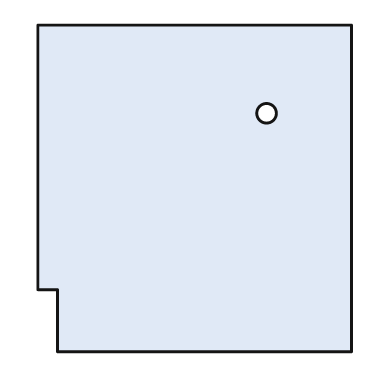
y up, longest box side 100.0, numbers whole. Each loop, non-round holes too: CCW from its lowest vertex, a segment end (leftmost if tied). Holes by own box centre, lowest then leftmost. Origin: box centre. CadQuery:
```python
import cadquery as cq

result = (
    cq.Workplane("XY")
    .moveTo(-42.0, -50.0)
    .lineTo(48.0, -50.0)
    .lineTo(48.0, 50.0)
    .lineTo(-48.0, 50.0)
    .lineTo(-48.0, -31.0)
    .lineTo(-42.0, -31.0)
    .close()
    .moveTo(22.0, 23.0)
    .circle(3.0)
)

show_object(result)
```